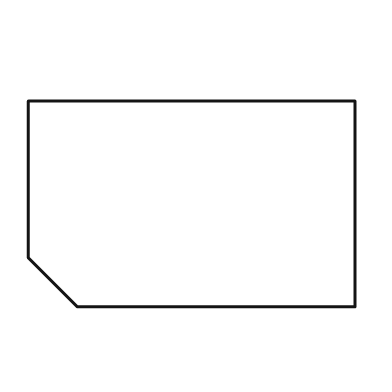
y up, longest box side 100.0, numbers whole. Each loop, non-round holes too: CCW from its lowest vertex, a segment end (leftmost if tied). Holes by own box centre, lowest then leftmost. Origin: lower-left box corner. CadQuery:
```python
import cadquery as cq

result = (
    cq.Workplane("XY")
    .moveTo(15.0, 0.0)
    .lineTo(100.0, 0.0)
    .lineTo(100.0, 63.0)
    .lineTo(0.0, 63.0)
    .lineTo(0.0, 15.0)
    .close()
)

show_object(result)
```